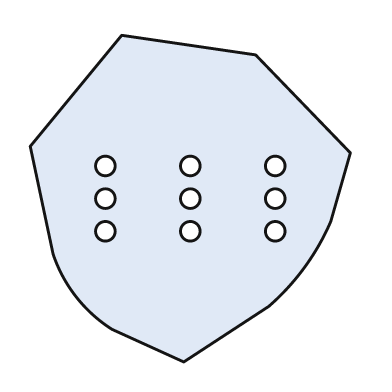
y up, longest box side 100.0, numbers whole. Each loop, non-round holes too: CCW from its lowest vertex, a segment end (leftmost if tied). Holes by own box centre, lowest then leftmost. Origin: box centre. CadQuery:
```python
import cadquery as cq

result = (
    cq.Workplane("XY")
    .moveTo(-2.0, -50.0)
    .lineTo(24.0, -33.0)
    .threePointArc((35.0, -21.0), (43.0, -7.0))
    .lineTo(49.0, 14.0)
    .lineTo(20.0, 44.0)
    .lineTo(-21.0, 50.0)
    .lineTo(-49.0, 16.0)
    .lineTo(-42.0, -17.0)
    .threePointArc((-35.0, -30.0), (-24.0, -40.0))
    .close()
    .moveTo(-26.0, -10.0)
    .circle(3.0)
    .moveTo(0.0, -10.0)
    .circle(3.0)
    .moveTo(26.0, -10.0)
    .circle(3.0)
    .moveTo(-26.0, 0.0)
    .circle(3.0)
    .moveTo(0.0, 0.0)
    .circle(3.0)
    .moveTo(26.0, 0.0)
    .circle(3.0)
    .moveTo(-26.0, 10.0)
    .circle(3.0)
    .moveTo(0.0, 10.0)
    .circle(3.0)
    .moveTo(26.0, 10.0)
    .circle(3.0)
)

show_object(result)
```